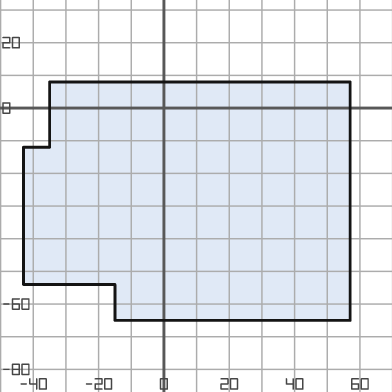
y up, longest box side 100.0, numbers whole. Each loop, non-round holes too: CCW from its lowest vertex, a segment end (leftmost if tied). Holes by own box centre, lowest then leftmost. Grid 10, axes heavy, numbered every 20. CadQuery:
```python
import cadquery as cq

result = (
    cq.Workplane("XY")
    .moveTo(-15.0, -65.0)
    .lineTo(57.0, -65.0)
    .lineTo(57.0, 8.0)
    .lineTo(-35.0, 8.0)
    .lineTo(-35.0, -12.0)
    .lineTo(-43.0, -12.0)
    .lineTo(-43.0, -54.0)
    .lineTo(-15.0, -54.0)
    .close()
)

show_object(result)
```